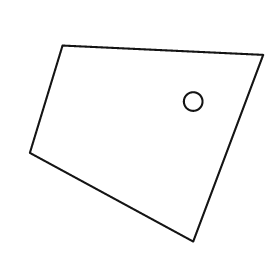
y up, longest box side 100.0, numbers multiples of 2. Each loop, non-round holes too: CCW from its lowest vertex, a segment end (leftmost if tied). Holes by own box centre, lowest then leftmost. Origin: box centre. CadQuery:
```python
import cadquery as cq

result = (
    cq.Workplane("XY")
    .moveTo(20.0, -42.0)
    .lineTo(50.0, 38.0)
    .lineTo(-36.0, 42.0)
    .lineTo(-50.0, -4.0)
    .close()
    .moveTo(20.0, 18.0)
    .circle(4.0)
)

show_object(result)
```